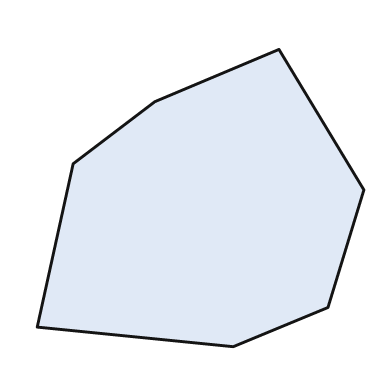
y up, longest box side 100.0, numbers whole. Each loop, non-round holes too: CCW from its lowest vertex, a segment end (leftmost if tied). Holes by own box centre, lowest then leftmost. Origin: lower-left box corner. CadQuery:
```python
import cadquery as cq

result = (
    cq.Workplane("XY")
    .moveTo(60.0, 0.0)
    .lineTo(89.0, 12.0)
    .lineTo(100.0, 48.0)
    .lineTo(74.0, 91.0)
    .lineTo(36.0, 75.0)
    .lineTo(11.0, 56.0)
    .lineTo(0.0, 6.0)
    .close()
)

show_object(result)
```